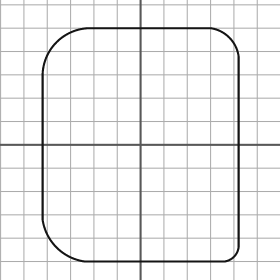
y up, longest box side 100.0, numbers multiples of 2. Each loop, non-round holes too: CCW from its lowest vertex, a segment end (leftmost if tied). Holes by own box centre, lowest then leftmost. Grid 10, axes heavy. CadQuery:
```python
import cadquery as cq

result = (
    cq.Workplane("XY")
    .moveTo(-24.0, -50.0)
    .lineTo(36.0, -50.0)
    .threePointArc((40.0, -48.0), (42.0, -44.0))
    .lineTo(42.0, 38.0)
    .threePointArc((38.0, 46.0), (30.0, 50.0))
    .lineTo(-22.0, 50.0)
    .threePointArc((-36.0, 44.0), (-42.0, 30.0))
    .lineTo(-42.0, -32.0)
    .threePointArc((-36.0, -44.0), (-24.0, -50.0))
    .close()
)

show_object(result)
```